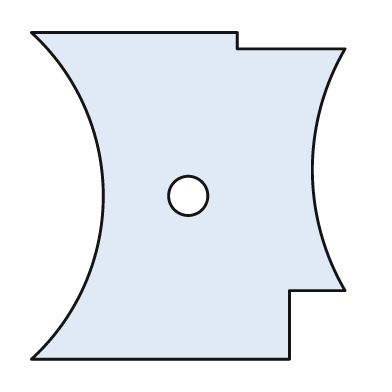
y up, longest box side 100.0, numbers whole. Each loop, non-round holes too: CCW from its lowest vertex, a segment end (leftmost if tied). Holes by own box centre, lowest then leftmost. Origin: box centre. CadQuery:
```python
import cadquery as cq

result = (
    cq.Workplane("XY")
    .moveTo(-48.0, -50.0)
    .lineTo(31.0, -50.0)
    .lineTo(31.0, -29.0)
    .lineTo(48.0, -29.0)
    .threePointArc((38.0, 8.0), (48.0, 45.0))
    .lineTo(15.0, 45.0)
    .lineTo(15.0, 50.0)
    .lineTo(-48.0, 50.0)
    .threePointArc((-26.0, 0.0), (-48.0, -50.0))
    .close()
    .moveTo(0.0, 0.0)
    .circle(6.0)
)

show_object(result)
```